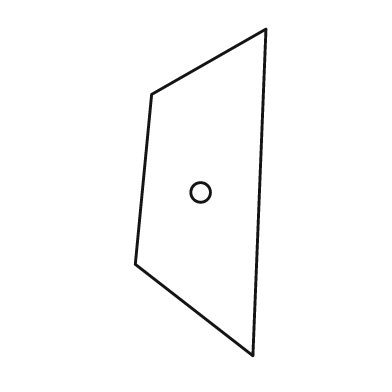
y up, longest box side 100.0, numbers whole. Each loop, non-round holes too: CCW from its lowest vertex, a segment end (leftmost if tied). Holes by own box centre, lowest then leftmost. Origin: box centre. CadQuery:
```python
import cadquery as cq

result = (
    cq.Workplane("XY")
    .moveTo(16.0, -50.0)
    .lineTo(20.0, 50.0)
    .lineTo(-15.0, 30.0)
    .lineTo(-20.0, -22.0)
    .close()
    .moveTo(0.0, 0.0)
    .circle(3.0)
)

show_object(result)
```